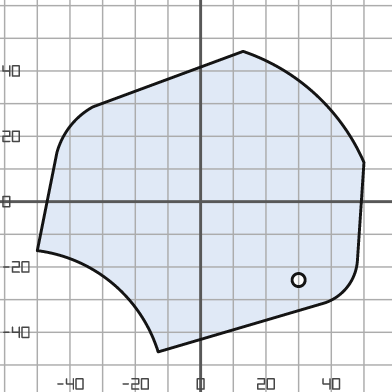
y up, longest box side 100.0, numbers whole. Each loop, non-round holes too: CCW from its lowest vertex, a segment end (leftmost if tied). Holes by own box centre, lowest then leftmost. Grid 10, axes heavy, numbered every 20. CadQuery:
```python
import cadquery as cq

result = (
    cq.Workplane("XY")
    .moveTo(-13.0, -46.0)
    .lineTo(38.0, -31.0)
    .threePointArc((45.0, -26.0), (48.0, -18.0))
    .lineTo(50.0, 12.0)
    .threePointArc((35.0, 33.0), (13.0, 46.0))
    .lineTo(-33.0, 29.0)
    .threePointArc((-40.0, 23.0), (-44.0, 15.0))
    .lineTo(-50.0, -15.0)
    .threePointArc((-27.0, -25.0), (-13.0, -46.0))
    .close()
    .moveTo(30.0, -24.0)
    .circle(2.0)
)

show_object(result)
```